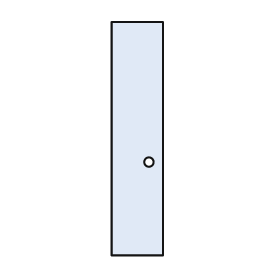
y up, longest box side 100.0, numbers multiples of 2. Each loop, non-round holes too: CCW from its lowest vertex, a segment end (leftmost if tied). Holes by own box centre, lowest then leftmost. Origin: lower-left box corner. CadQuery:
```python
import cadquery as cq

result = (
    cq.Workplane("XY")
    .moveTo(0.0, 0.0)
    .lineTo(22.0, 0.0)
    .lineTo(22.0, 100.0)
    .lineTo(0.0, 100.0)
    .close()
    .moveTo(16.0, 40.0)
    .circle(2.0)
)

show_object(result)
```